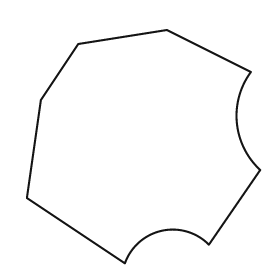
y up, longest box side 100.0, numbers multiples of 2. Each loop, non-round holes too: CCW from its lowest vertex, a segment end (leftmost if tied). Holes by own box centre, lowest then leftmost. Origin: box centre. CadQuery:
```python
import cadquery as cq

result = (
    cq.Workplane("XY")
    .moveTo(-8.0, -50.0)
    .threePointArc((8.0, -36.0), (28.0, -42.0))
    .lineTo(50.0, -10.0)
    .threePointArc((40.0, 10.0), (46.0, 32.0))
    .lineTo(10.0, 50.0)
    .lineTo(-28.0, 44.0)
    .lineTo(-44.0, 20.0)
    .lineTo(-50.0, -22.0)
    .close()
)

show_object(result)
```